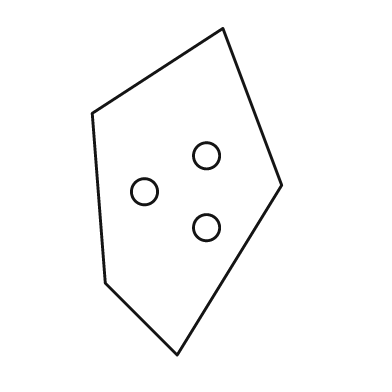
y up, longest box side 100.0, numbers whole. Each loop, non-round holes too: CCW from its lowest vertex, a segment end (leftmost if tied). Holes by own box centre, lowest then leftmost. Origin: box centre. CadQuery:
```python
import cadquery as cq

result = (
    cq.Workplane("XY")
    .moveTo(-3.0, -50.0)
    .lineTo(29.0, 2.0)
    .lineTo(11.0, 50.0)
    .lineTo(-29.0, 24.0)
    .lineTo(-25.0, -28.0)
    .close()
    .moveTo(6.0, -11.0)
    .circle(4.0)
    .moveTo(-13.0, 0.0)
    .circle(4.0)
    .moveTo(6.0, 11.0)
    .circle(4.0)
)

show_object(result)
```